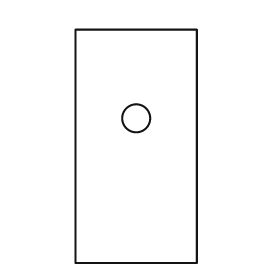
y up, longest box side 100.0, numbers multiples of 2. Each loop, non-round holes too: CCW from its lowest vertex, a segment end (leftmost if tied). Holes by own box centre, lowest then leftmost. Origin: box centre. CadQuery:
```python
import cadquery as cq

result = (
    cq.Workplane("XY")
    .moveTo(-26.0, -50.0)
    .lineTo(26.0, -50.0)
    .lineTo(26.0, 50.0)
    .lineTo(-26.0, 50.0)
    .close()
    .moveTo(0.0, 12.0)
    .circle(6.0)
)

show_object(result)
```